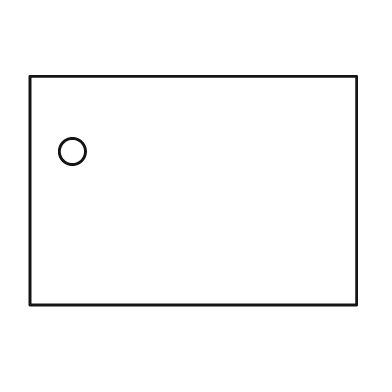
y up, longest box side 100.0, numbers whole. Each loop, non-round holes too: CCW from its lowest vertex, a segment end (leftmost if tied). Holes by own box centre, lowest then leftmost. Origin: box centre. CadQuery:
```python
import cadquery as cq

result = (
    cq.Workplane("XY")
    .moveTo(-50.0, -35.0)
    .lineTo(50.0, -35.0)
    .lineTo(50.0, 35.0)
    .lineTo(-50.0, 35.0)
    .close()
    .moveTo(-37.0, 12.0)
    .circle(4.0)
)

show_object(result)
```